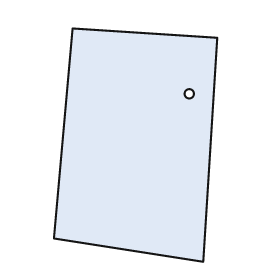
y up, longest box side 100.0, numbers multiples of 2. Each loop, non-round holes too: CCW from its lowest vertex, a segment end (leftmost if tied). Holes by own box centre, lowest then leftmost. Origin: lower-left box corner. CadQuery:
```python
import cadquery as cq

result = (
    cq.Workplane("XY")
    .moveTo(64.0, 0.0)
    .lineTo(70.0, 96.0)
    .lineTo(8.0, 100.0)
    .lineTo(0.0, 10.0)
    .close()
    .moveTo(58.0, 72.0)
    .circle(2.0)
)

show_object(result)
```